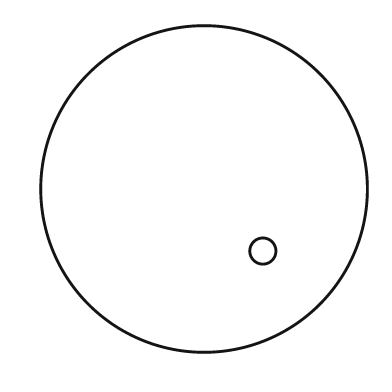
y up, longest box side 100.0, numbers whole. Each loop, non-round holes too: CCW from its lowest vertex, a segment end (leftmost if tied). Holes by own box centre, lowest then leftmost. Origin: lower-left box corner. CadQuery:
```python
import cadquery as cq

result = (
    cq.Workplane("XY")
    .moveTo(50.0, 50.0)
    .circle(50.0)
    .moveTo(68.0, 31.0)
    .circle(4.0)
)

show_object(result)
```